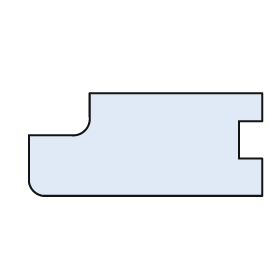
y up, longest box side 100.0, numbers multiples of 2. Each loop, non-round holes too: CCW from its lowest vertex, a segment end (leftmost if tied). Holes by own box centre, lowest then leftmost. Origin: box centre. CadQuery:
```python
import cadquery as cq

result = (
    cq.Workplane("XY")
    .moveTo(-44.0, -22.0)
    .lineTo(50.0, -22.0)
    .lineTo(50.0, -6.0)
    .lineTo(40.0, -6.0)
    .lineTo(40.0, 10.0)
    .lineTo(50.0, 10.0)
    .lineTo(50.0, 22.0)
    .lineTo(-24.0, 22.0)
    .lineTo(-24.0, 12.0)
    .threePointArc((-26.0, 6.0), (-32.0, 4.0))
    .lineTo(-50.0, 4.0)
    .lineTo(-50.0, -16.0)
    .threePointArc((-48.0, -20.0), (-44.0, -22.0))
    .close()
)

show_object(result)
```